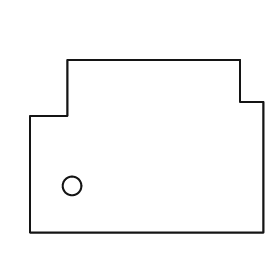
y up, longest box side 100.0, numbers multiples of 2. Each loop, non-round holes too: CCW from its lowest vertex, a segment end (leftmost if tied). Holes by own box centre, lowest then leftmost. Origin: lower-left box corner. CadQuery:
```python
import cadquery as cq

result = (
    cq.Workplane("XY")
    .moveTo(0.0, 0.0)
    .lineTo(100.0, 0.0)
    .lineTo(100.0, 56.0)
    .lineTo(90.0, 56.0)
    .lineTo(90.0, 74.0)
    .lineTo(16.0, 74.0)
    .lineTo(16.0, 50.0)
    .lineTo(0.0, 50.0)
    .close()
    .moveTo(18.0, 20.0)
    .circle(4.0)
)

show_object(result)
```